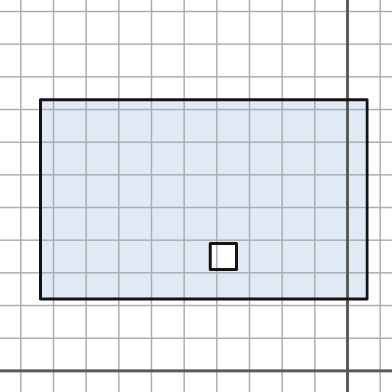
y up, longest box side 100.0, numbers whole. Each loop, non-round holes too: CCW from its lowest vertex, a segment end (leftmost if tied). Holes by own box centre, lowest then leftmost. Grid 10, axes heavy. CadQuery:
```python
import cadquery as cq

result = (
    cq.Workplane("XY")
    .moveTo(-94.0, 22.0)
    .lineTo(6.0, 22.0)
    .lineTo(6.0, 83.0)
    .lineTo(-94.0, 83.0)
    .close()
    .moveTo(-42.0, 31.0)
    .lineTo(-34.0, 31.0)
    .lineTo(-34.0, 39.0)
    .lineTo(-42.0, 39.0)
    .close()
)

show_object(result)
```